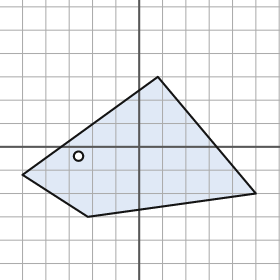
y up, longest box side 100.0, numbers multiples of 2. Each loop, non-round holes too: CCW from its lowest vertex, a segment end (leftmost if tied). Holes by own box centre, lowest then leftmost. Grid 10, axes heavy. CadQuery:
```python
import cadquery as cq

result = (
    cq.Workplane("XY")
    .moveTo(-22.0, -30.0)
    .lineTo(50.0, -20.0)
    .lineTo(8.0, 30.0)
    .lineTo(-50.0, -12.0)
    .close()
    .moveTo(-26.0, -4.0)
    .circle(2.0)
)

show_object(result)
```